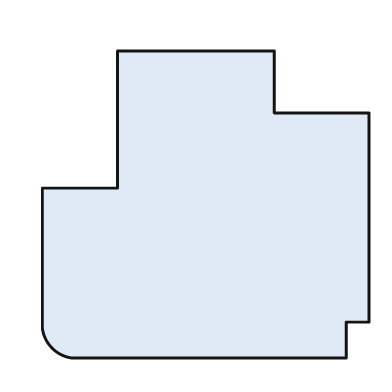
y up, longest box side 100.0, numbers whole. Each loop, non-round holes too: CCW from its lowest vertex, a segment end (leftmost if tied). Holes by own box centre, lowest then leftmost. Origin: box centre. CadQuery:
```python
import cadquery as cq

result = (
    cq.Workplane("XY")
    .moveTo(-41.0, -47.0)
    .lineTo(43.0, -47.0)
    .lineTo(43.0, -36.0)
    .lineTo(50.0, -36.0)
    .lineTo(50.0, 28.0)
    .lineTo(21.0, 28.0)
    .lineTo(21.0, 47.0)
    .lineTo(-27.0, 47.0)
    .lineTo(-27.0, 5.0)
    .lineTo(-50.0, 5.0)
    .lineTo(-50.0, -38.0)
    .threePointArc((-47.0, -44.0), (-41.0, -47.0))
    .close()
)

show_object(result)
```